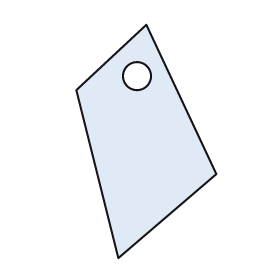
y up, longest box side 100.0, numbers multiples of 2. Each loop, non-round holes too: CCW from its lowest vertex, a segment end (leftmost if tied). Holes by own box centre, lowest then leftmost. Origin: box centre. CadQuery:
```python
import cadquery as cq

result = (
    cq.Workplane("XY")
    .moveTo(-12.0, -50.0)
    .lineTo(30.0, -14.0)
    .lineTo(0.0, 50.0)
    .lineTo(-30.0, 22.0)
    .close()
    .moveTo(-4.0, 28.0)
    .circle(6.0)
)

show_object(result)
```